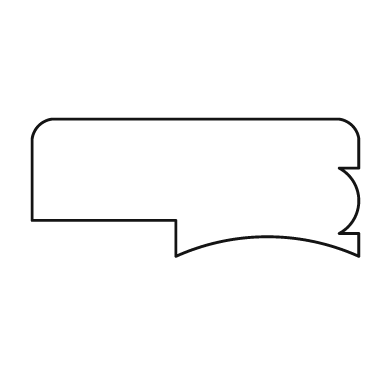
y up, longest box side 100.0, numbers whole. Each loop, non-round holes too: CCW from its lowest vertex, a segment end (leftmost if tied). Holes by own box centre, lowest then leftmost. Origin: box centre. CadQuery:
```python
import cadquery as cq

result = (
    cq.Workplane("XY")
    .moveTo(-6.0, -21.0)
    .threePointArc((22.0, -15.0), (50.0, -21.0))
    .lineTo(50.0, -14.0)
    .lineTo(44.0, -14.0)
    .threePointArc((50.0, -4.0), (44.0, 6.0))
    .lineTo(50.0, 6.0)
    .lineTo(50.0, 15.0)
    .threePointArc((48.0, 19.0), (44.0, 21.0))
    .lineTo(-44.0, 21.0)
    .threePointArc((-48.0, 19.0), (-50.0, 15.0))
    .lineTo(-50.0, -10.0)
    .lineTo(-6.0, -10.0)
    .close()
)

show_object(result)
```